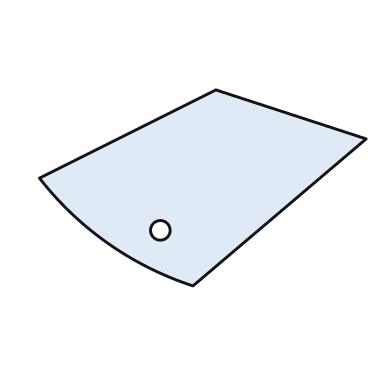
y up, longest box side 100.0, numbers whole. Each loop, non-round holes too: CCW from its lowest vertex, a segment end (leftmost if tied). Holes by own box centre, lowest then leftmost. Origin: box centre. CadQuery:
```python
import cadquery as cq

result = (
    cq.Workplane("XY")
    .moveTo(-3.0, -30.0)
    .lineTo(50.0, 15.0)
    .lineTo(4.0, 30.0)
    .lineTo(-50.0, 3.0)
    .threePointArc((-29.0, -17.0), (-3.0, -30.0))
    .close()
    .moveTo(-13.0, -13.0)
    .circle(3.0)
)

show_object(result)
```